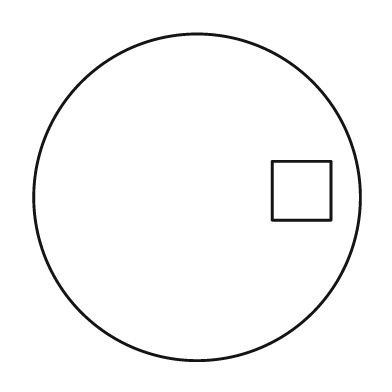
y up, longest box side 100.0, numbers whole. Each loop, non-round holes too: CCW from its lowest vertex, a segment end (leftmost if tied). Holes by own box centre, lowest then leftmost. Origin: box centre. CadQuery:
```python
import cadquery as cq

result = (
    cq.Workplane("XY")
    .moveTo(0.0, 0.0)
    .circle(50.0)
    .moveTo(23.0, -7.0)
    .lineTo(41.0, -7.0)
    .lineTo(41.0, 11.0)
    .lineTo(23.0, 11.0)
    .close()
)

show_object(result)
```